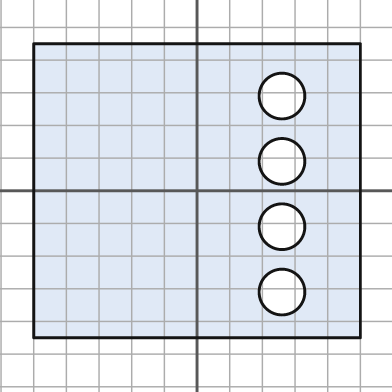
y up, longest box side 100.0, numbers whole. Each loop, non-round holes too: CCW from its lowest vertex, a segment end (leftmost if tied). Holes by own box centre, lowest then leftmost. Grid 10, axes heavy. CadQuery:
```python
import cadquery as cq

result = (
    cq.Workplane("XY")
    .moveTo(-50.0, -45.0)
    .lineTo(50.0, -45.0)
    .lineTo(50.0, 45.0)
    .lineTo(-50.0, 45.0)
    .close()
    .moveTo(26.0, -31.0)
    .circle(7.0)
    .moveTo(26.0, -11.0)
    .circle(7.0)
    .moveTo(26.0, 9.0)
    .circle(7.0)
    .moveTo(26.0, 29.0)
    .circle(7.0)
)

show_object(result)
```